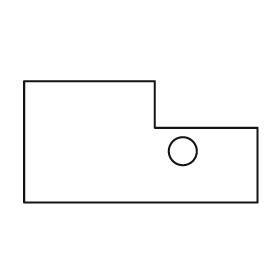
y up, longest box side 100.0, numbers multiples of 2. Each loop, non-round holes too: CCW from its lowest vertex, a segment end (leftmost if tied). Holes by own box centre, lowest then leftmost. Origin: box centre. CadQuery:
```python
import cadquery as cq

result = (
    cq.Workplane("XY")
    .moveTo(-50.0, -26.0)
    .lineTo(50.0, -26.0)
    .lineTo(50.0, 6.0)
    .lineTo(6.0, 6.0)
    .lineTo(6.0, 26.0)
    .lineTo(-50.0, 26.0)
    .close()
    .moveTo(18.0, -4.0)
    .circle(6.0)
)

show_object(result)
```